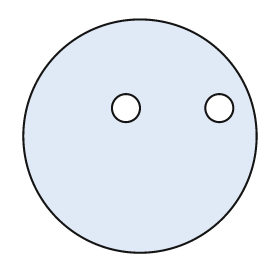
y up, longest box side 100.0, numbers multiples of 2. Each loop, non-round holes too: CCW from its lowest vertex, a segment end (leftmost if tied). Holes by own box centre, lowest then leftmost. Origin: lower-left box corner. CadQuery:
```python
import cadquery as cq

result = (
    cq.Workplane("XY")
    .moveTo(50.0, 50.0)
    .circle(50.0)
    .moveTo(44.0, 62.0)
    .circle(6.0)
    .moveTo(84.0, 62.0)
    .circle(6.0)
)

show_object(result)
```